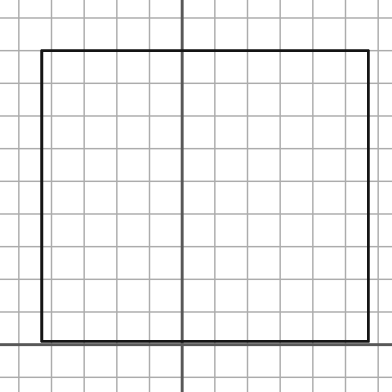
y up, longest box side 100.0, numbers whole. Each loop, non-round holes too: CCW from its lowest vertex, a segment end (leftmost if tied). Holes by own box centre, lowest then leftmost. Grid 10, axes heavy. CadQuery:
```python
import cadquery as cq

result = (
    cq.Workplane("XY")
    .moveTo(-43.0, 1.0)
    .lineTo(57.0, 1.0)
    .lineTo(57.0, 90.0)
    .lineTo(-43.0, 90.0)
    .close()
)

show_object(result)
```